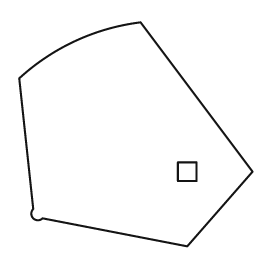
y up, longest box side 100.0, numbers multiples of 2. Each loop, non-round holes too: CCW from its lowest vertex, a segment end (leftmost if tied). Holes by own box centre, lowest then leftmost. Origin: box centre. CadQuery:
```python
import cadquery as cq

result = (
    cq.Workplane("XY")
    .moveTo(22.0, -48.0)
    .lineTo(50.0, -16.0)
    .lineTo(2.0, 48.0)
    .threePointArc((-26.0, 40.0), (-50.0, 24.0))
    .lineTo(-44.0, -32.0)
    .threePointArc((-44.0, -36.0), (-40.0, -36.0))
    .close()
    .moveTo(18.0, -20.0)
    .lineTo(26.0, -20.0)
    .lineTo(26.0, -12.0)
    .lineTo(18.0, -12.0)
    .close()
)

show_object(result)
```